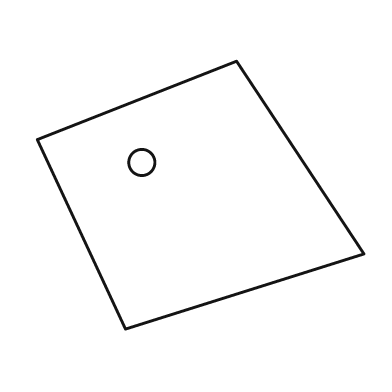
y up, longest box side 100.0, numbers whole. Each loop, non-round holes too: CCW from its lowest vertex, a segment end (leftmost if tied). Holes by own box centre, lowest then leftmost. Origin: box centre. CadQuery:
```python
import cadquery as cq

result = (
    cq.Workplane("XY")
    .moveTo(-23.0, -41.0)
    .lineTo(50.0, -18.0)
    .lineTo(11.0, 41.0)
    .lineTo(-50.0, 17.0)
    .close()
    .moveTo(-18.0, 10.0)
    .circle(4.0)
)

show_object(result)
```